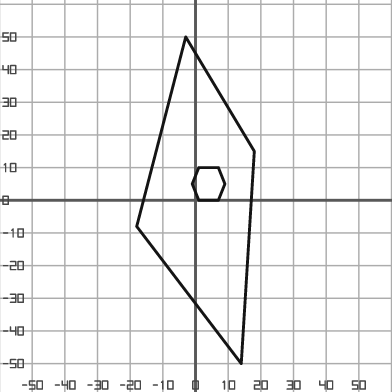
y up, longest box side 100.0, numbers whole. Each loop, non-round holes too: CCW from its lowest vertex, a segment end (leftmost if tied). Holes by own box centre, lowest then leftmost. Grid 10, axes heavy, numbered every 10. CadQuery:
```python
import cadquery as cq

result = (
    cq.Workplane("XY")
    .moveTo(14.0, -50.0)
    .lineTo(18.0, 15.0)
    .lineTo(-3.0, 50.0)
    .lineTo(-18.0, -8.0)
    .close()
    .moveTo(1.0, 0.0)
    .lineTo(7.0, 0.0)
    .lineTo(9.0, 5.0)
    .lineTo(7.0, 10.0)
    .lineTo(1.0, 10.0)
    .lineTo(-1.0, 5.0)
    .close()
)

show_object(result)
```